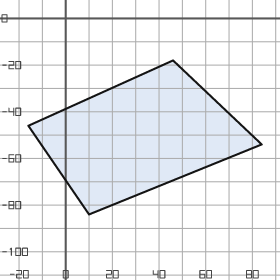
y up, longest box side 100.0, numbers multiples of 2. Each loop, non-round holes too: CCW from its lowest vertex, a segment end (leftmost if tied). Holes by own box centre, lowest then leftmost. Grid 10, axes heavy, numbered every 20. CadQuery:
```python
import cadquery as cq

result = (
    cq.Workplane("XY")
    .moveTo(10.0, -84.0)
    .lineTo(84.0, -54.0)
    .lineTo(46.0, -18.0)
    .lineTo(-16.0, -46.0)
    .close()
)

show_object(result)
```